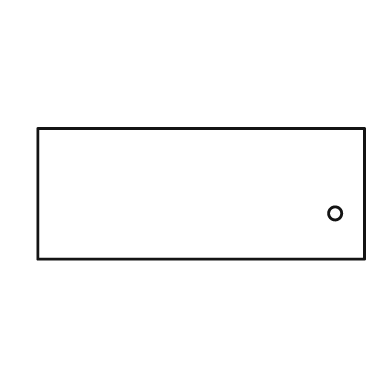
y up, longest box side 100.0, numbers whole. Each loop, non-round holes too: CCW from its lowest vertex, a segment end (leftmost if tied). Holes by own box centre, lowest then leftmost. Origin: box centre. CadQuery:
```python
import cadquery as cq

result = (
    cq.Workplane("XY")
    .moveTo(-50.0, -20.0)
    .lineTo(50.0, -20.0)
    .lineTo(50.0, 20.0)
    .lineTo(-50.0, 20.0)
    .close()
    .moveTo(41.0, -6.0)
    .circle(2.0)
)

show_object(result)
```